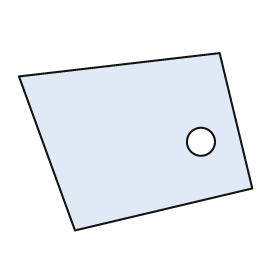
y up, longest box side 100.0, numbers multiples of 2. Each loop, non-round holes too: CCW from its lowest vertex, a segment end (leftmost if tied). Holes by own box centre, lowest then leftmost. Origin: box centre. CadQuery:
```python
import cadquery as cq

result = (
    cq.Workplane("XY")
    .moveTo(-26.0, -38.0)
    .lineTo(50.0, -20.0)
    .lineTo(36.0, 38.0)
    .lineTo(-50.0, 28.0)
    .close()
    .moveTo(28.0, 0.0)
    .circle(6.0)
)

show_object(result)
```